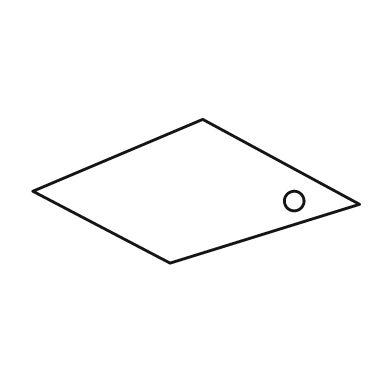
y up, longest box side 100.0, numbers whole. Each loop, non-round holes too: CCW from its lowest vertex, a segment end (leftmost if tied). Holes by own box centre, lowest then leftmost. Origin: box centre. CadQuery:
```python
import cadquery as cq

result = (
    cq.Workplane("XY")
    .moveTo(-8.0, -22.0)
    .lineTo(50.0, -4.0)
    .lineTo(2.0, 22.0)
    .lineTo(-50.0, 0.0)
    .close()
    .moveTo(30.0, -3.0)
    .circle(3.0)
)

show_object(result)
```